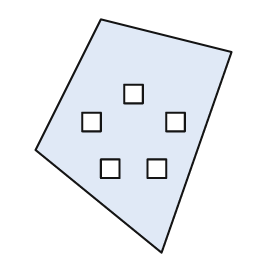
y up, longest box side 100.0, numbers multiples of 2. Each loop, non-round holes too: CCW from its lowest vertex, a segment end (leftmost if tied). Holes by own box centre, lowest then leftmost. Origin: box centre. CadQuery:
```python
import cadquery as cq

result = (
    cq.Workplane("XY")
    .moveTo(12.0, -50.0)
    .lineTo(42.0, 36.0)
    .lineTo(-14.0, 50.0)
    .lineTo(-42.0, -6.0)
    .close()
    .moveTo(-14.0, -18.0)
    .lineTo(-6.0, -18.0)
    .lineTo(-6.0, -10.0)
    .lineTo(-14.0, -10.0)
    .close()
    .moveTo(6.0, -18.0)
    .lineTo(14.0, -18.0)
    .lineTo(14.0, -10.0)
    .lineTo(6.0, -10.0)
    .close()
    .moveTo(-22.0, 2.0)
    .lineTo(-14.0, 2.0)
    .lineTo(-14.0, 10.0)
    .lineTo(-22.0, 10.0)
    .close()
    .moveTo(14.0, 2.0)
    .lineTo(22.0, 2.0)
    .lineTo(22.0, 10.0)
    .lineTo(14.0, 10.0)
    .close()
    .moveTo(-4.0, 14.0)
    .lineTo(4.0, 14.0)
    .lineTo(4.0, 22.0)
    .lineTo(-4.0, 22.0)
    .close()
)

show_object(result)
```